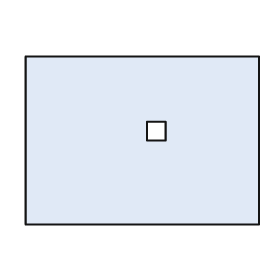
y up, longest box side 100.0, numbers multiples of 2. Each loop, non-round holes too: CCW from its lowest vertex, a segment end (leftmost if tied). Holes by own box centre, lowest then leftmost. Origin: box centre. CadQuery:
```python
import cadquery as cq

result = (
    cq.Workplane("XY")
    .moveTo(-50.0, -36.0)
    .lineTo(50.0, -36.0)
    .lineTo(50.0, 36.0)
    .lineTo(-50.0, 36.0)
    .close()
    .moveTo(2.0, 0.0)
    .lineTo(10.0, 0.0)
    .lineTo(10.0, 8.0)
    .lineTo(2.0, 8.0)
    .close()
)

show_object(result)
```